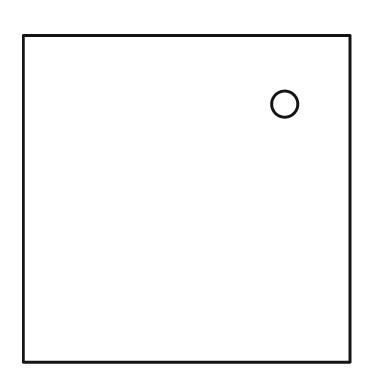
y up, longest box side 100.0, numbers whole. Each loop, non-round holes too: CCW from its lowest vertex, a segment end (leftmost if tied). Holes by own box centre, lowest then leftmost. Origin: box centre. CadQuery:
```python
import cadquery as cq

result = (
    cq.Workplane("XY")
    .moveTo(-50.0, -50.0)
    .lineTo(50.0, -50.0)
    .lineTo(50.0, 50.0)
    .lineTo(-50.0, 50.0)
    .close()
    .moveTo(30.0, 29.0)
    .circle(4.0)
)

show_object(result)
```